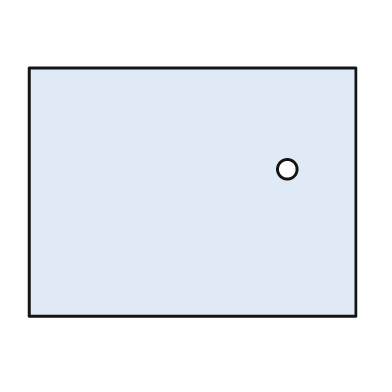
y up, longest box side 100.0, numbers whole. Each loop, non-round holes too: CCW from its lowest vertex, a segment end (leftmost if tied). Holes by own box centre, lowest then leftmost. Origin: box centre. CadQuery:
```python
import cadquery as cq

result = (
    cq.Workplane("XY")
    .moveTo(-50.0, -38.0)
    .lineTo(50.0, -38.0)
    .lineTo(50.0, 38.0)
    .lineTo(-50.0, 38.0)
    .close()
    .moveTo(29.0, 7.0)
    .circle(3.0)
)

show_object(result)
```